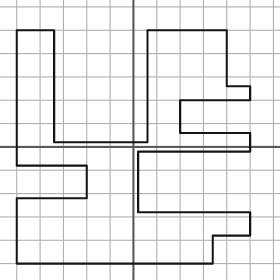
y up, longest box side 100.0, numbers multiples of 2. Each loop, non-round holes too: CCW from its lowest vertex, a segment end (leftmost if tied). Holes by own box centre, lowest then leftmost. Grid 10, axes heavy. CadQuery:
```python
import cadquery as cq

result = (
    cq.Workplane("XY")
    .moveTo(-50.0, -50.0)
    .lineTo(34.0, -50.0)
    .lineTo(34.0, -38.0)
    .lineTo(50.0, -38.0)
    .lineTo(50.0, -28.0)
    .lineTo(2.0, -28.0)
    .lineTo(2.0, -2.0)
    .lineTo(50.0, -2.0)
    .lineTo(50.0, 6.0)
    .lineTo(20.0, 6.0)
    .lineTo(20.0, 20.0)
    .lineTo(50.0, 20.0)
    .lineTo(50.0, 26.0)
    .lineTo(40.0, 26.0)
    .lineTo(40.0, 50.0)
    .lineTo(6.0, 50.0)
    .lineTo(6.0, 2.0)
    .lineTo(-34.0, 2.0)
    .lineTo(-34.0, 50.0)
    .lineTo(-50.0, 50.0)
    .lineTo(-50.0, -8.0)
    .lineTo(-20.0, -8.0)
    .lineTo(-20.0, -22.0)
    .lineTo(-50.0, -22.0)
    .close()
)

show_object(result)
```